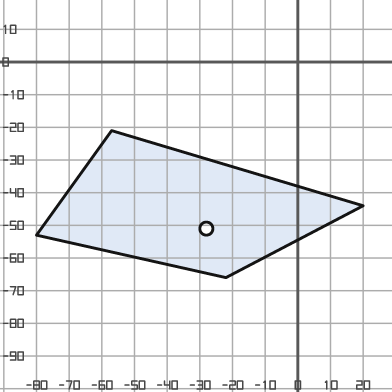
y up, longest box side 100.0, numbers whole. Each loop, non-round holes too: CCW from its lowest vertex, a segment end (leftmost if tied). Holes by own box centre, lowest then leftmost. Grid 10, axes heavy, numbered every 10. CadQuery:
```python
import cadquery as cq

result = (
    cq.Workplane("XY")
    .moveTo(-22.0, -66.0)
    .lineTo(20.0, -44.0)
    .lineTo(-57.0, -21.0)
    .lineTo(-80.0, -53.0)
    .close()
    .moveTo(-28.0, -51.0)
    .circle(2.0)
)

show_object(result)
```